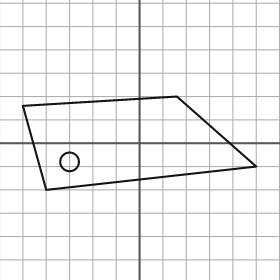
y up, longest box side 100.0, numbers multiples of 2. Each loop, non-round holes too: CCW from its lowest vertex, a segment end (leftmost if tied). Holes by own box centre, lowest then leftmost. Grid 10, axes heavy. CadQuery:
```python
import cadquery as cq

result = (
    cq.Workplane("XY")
    .moveTo(-40.0, -20.0)
    .lineTo(50.0, -10.0)
    .lineTo(16.0, 20.0)
    .lineTo(-50.0, 16.0)
    .close()
    .moveTo(-30.0, -8.0)
    .circle(4.0)
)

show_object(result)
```